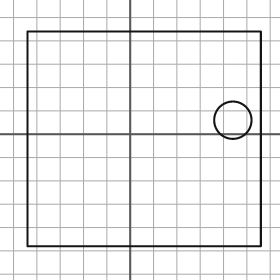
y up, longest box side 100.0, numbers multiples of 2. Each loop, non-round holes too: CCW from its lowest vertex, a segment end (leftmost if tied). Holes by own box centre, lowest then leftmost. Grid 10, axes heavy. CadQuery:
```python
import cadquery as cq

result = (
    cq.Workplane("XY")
    .moveTo(-44.0, -48.0)
    .lineTo(56.0, -48.0)
    .lineTo(56.0, 44.0)
    .lineTo(-44.0, 44.0)
    .close()
    .moveTo(44.0, 6.0)
    .circle(8.0)
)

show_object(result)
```